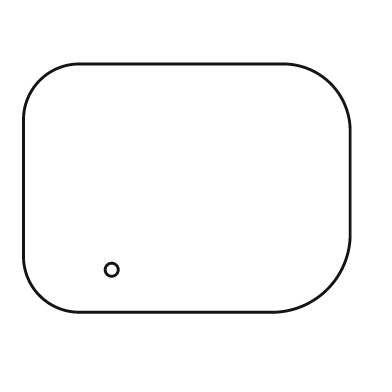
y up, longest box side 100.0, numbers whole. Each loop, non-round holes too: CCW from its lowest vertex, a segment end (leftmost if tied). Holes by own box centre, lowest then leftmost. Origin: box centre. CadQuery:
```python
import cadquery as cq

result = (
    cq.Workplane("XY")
    .moveTo(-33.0, -38.0)
    .lineTo(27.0, -38.0)
    .threePointArc((43.0, -31.0), (50.0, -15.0))
    .lineTo(50.0, 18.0)
    .threePointArc((44.0, 32.0), (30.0, 38.0))
    .lineTo(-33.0, 38.0)
    .threePointArc((-45.0, 33.0), (-50.0, 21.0))
    .lineTo(-50.0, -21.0)
    .threePointArc((-45.0, -33.0), (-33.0, -38.0))
    .close()
    .moveTo(-23.0, -25.0)
    .circle(2.0)
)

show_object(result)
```